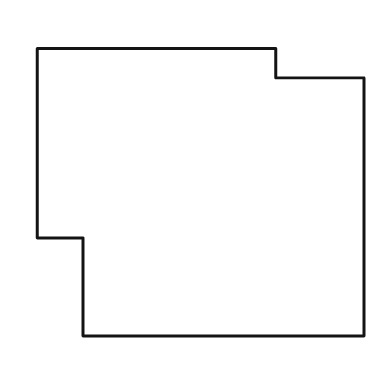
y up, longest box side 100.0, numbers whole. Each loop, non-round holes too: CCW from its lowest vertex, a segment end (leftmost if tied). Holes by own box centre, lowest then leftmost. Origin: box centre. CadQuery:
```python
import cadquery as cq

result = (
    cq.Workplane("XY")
    .moveTo(-36.0, -44.0)
    .lineTo(50.0, -44.0)
    .lineTo(50.0, 35.0)
    .lineTo(23.0, 35.0)
    .lineTo(23.0, 44.0)
    .lineTo(-50.0, 44.0)
    .lineTo(-50.0, -14.0)
    .lineTo(-36.0, -14.0)
    .close()
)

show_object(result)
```